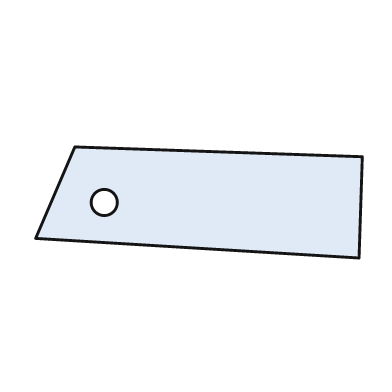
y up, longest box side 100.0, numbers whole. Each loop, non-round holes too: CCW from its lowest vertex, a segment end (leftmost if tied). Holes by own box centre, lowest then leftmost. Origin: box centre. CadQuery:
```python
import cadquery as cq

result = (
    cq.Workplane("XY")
    .moveTo(49.0, -17.0)
    .lineTo(50.0, 14.0)
    .lineTo(-38.0, 17.0)
    .lineTo(-50.0, -11.0)
    .close()
    .moveTo(-29.0, 0.0)
    .circle(4.0)
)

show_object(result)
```